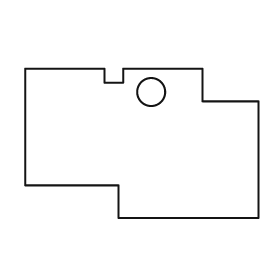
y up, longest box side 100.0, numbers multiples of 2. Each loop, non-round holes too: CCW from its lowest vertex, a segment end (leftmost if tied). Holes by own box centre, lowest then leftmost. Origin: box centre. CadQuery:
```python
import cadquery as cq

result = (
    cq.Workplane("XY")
    .moveTo(-10.0, -32.0)
    .lineTo(50.0, -32.0)
    .lineTo(50.0, 18.0)
    .lineTo(26.0, 18.0)
    .lineTo(26.0, 32.0)
    .lineTo(-8.0, 32.0)
    .lineTo(-8.0, 26.0)
    .lineTo(-16.0, 26.0)
    .lineTo(-16.0, 32.0)
    .lineTo(-50.0, 32.0)
    .lineTo(-50.0, -18.0)
    .lineTo(-10.0, -18.0)
    .close()
    .moveTo(4.0, 22.0)
    .circle(6.0)
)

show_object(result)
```